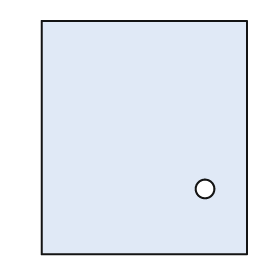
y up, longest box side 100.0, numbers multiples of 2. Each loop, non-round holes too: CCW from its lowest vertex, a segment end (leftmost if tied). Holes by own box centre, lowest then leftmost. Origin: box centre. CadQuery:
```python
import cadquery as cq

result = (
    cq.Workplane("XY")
    .moveTo(-44.0, -50.0)
    .lineTo(44.0, -50.0)
    .lineTo(44.0, 50.0)
    .lineTo(-44.0, 50.0)
    .close()
    .moveTo(26.0, -22.0)
    .circle(4.0)
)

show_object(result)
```